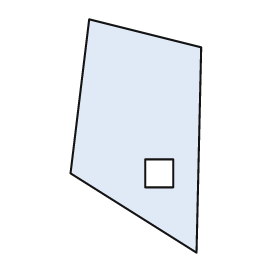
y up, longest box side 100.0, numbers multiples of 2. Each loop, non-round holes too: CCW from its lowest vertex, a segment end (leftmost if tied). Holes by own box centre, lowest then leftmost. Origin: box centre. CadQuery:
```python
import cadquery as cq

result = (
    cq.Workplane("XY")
    .moveTo(26.0, -50.0)
    .lineTo(28.0, 38.0)
    .lineTo(-20.0, 50.0)
    .lineTo(-28.0, -16.0)
    .close()
    .moveTo(4.0, -22.0)
    .lineTo(16.0, -22.0)
    .lineTo(16.0, -10.0)
    .lineTo(4.0, -10.0)
    .close()
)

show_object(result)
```